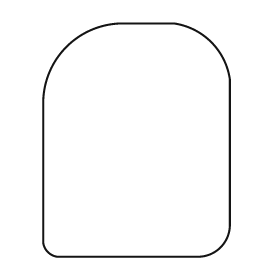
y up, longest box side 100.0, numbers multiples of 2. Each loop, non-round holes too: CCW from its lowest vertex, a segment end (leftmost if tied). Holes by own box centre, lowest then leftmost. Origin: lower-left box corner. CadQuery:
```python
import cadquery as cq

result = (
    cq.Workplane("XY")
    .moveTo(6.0, 0.0)
    .lineTo(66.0, 0.0)
    .threePointArc((76.0, 4.0), (80.0, 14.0))
    .lineTo(80.0, 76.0)
    .threePointArc((72.0, 92.0), (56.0, 100.0))
    .lineTo(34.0, 100.0)
    .threePointArc((10.0, 90.0), (0.0, 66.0))
    .lineTo(0.0, 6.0)
    .threePointArc((2.0, 2.0), (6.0, 0.0))
    .close()
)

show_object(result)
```